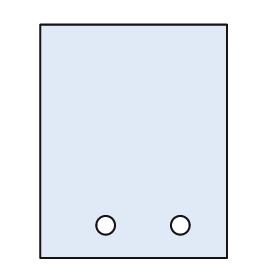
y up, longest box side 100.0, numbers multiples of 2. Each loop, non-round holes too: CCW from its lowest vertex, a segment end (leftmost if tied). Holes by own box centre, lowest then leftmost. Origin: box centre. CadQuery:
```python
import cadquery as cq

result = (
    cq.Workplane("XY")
    .moveTo(-40.0, -50.0)
    .lineTo(40.0, -50.0)
    .lineTo(40.0, 50.0)
    .lineTo(-40.0, 50.0)
    .close()
    .moveTo(-12.0, -36.0)
    .circle(4.0)
    .moveTo(20.0, -36.0)
    .circle(4.0)
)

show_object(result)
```